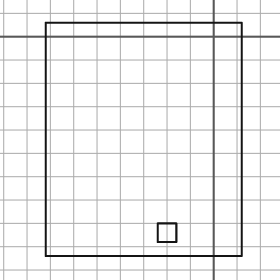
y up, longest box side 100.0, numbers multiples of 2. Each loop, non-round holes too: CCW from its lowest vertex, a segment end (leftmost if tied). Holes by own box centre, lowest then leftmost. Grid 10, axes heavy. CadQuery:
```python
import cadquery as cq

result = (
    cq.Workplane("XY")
    .moveTo(-72.0, -94.0)
    .lineTo(12.0, -94.0)
    .lineTo(12.0, 6.0)
    .lineTo(-72.0, 6.0)
    .close()
    .moveTo(-24.0, -88.0)
    .lineTo(-16.0, -88.0)
    .lineTo(-16.0, -80.0)
    .lineTo(-24.0, -80.0)
    .close()
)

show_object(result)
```